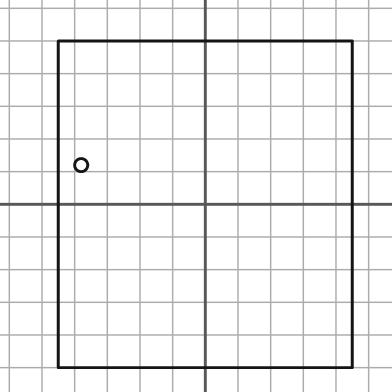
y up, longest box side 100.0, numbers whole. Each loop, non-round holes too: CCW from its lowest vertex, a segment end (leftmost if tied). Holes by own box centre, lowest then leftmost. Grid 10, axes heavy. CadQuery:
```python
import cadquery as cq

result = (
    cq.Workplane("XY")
    .moveTo(-45.0, -50.0)
    .lineTo(45.0, -50.0)
    .lineTo(45.0, 50.0)
    .lineTo(-45.0, 50.0)
    .close()
    .moveTo(-38.0, 12.0)
    .circle(2.0)
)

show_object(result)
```